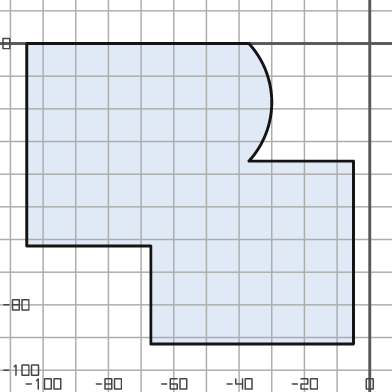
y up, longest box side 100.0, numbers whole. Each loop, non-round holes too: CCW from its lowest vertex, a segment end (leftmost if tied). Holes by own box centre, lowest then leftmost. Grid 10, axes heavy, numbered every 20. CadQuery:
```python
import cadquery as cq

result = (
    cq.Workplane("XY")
    .moveTo(-67.0, -92.0)
    .lineTo(-5.0, -92.0)
    .lineTo(-5.0, -36.0)
    .lineTo(-37.0, -36.0)
    .threePointArc((-30.0, -18.0), (-37.0, 0.0))
    .lineTo(-105.0, 0.0)
    .lineTo(-105.0, -62.0)
    .lineTo(-67.0, -62.0)
    .close()
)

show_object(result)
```